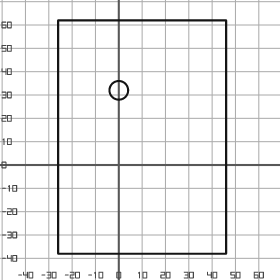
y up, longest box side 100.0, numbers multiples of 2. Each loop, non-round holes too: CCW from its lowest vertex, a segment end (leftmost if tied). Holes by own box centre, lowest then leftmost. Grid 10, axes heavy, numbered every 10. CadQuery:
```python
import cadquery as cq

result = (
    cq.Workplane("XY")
    .moveTo(-26.0, -38.0)
    .lineTo(46.0, -38.0)
    .lineTo(46.0, 62.0)
    .lineTo(-26.0, 62.0)
    .close()
    .moveTo(0.0, 32.0)
    .circle(4.0)
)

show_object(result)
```